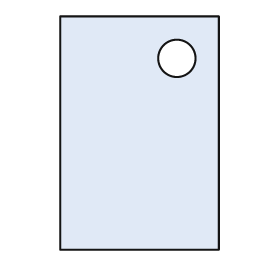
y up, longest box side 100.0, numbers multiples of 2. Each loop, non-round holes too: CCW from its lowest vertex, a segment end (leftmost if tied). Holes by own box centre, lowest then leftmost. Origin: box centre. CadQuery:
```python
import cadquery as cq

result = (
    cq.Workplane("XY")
    .moveTo(-34.0, -50.0)
    .lineTo(34.0, -50.0)
    .lineTo(34.0, 50.0)
    .lineTo(-34.0, 50.0)
    .close()
    .moveTo(16.0, 32.0)
    .circle(8.0)
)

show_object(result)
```